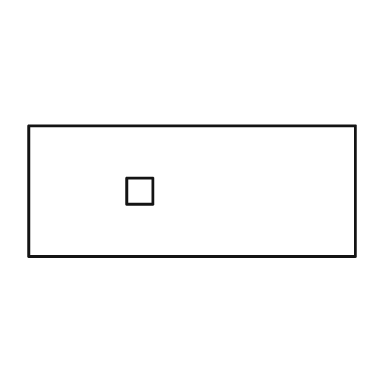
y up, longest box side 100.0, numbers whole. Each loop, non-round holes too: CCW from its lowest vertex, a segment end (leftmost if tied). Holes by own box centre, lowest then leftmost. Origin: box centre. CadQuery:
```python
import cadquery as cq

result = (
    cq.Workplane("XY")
    .moveTo(-50.0, -20.0)
    .lineTo(50.0, -20.0)
    .lineTo(50.0, 20.0)
    .lineTo(-50.0, 20.0)
    .close()
    .moveTo(-20.0, -4.0)
    .lineTo(-12.0, -4.0)
    .lineTo(-12.0, 4.0)
    .lineTo(-20.0, 4.0)
    .close()
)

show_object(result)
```